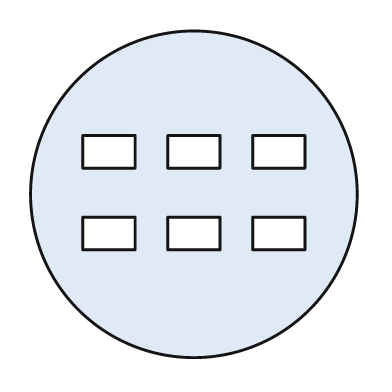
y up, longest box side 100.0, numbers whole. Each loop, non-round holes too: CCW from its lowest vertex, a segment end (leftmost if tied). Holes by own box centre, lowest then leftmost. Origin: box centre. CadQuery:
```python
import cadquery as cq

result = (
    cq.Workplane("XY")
    .moveTo(0.0, 0.0)
    .circle(50.0)
    .moveTo(-34.0, -17.0)
    .lineTo(-18.0, -17.0)
    .lineTo(-18.0, -7.0)
    .lineTo(-34.0, -7.0)
    .close()
    .moveTo(-8.0, -17.0)
    .lineTo(8.0, -17.0)
    .lineTo(8.0, -7.0)
    .lineTo(-8.0, -7.0)
    .close()
    .moveTo(18.0, -17.0)
    .lineTo(34.0, -17.0)
    .lineTo(34.0, -7.0)
    .lineTo(18.0, -7.0)
    .close()
    .moveTo(-34.0, 8.0)
    .lineTo(-18.0, 8.0)
    .lineTo(-18.0, 18.0)
    .lineTo(-34.0, 18.0)
    .close()
    .moveTo(-8.0, 8.0)
    .lineTo(8.0, 8.0)
    .lineTo(8.0, 18.0)
    .lineTo(-8.0, 18.0)
    .close()
    .moveTo(18.0, 8.0)
    .lineTo(34.0, 8.0)
    .lineTo(34.0, 18.0)
    .lineTo(18.0, 18.0)
    .close()
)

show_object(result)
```